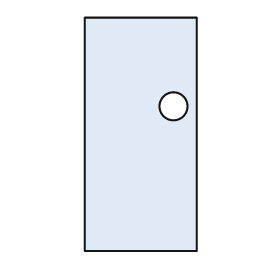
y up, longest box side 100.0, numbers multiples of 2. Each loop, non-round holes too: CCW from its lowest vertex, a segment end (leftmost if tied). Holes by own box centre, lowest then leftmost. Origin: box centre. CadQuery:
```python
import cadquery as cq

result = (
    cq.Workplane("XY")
    .moveTo(-24.0, -50.0)
    .lineTo(24.0, -50.0)
    .lineTo(24.0, 50.0)
    .lineTo(-24.0, 50.0)
    .close()
    .moveTo(14.0, 12.0)
    .circle(6.0)
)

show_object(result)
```